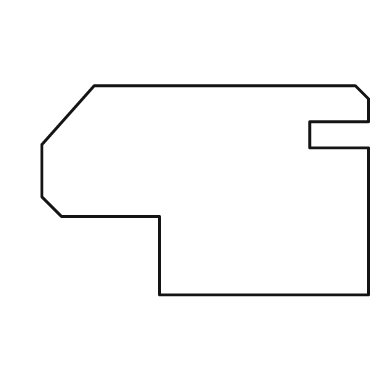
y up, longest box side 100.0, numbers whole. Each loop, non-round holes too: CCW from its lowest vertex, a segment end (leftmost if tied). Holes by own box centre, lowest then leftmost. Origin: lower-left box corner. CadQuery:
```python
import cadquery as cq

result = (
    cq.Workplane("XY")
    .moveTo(36.0, 0.0)
    .lineTo(100.0, 0.0)
    .lineTo(100.0, 45.0)
    .lineTo(82.0, 45.0)
    .lineTo(82.0, 53.0)
    .lineTo(100.0, 53.0)
    .lineTo(100.0, 60.0)
    .lineTo(96.0, 64.0)
    .lineTo(16.0, 64.0)
    .lineTo(0.0, 46.0)
    .lineTo(0.0, 30.0)
    .lineTo(6.0, 24.0)
    .lineTo(36.0, 24.0)
    .close()
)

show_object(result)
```